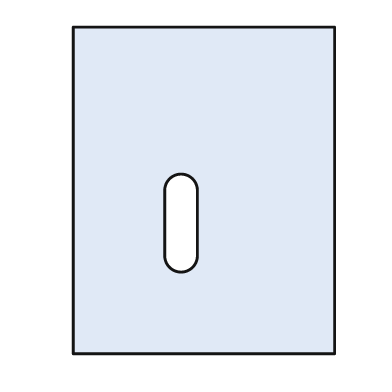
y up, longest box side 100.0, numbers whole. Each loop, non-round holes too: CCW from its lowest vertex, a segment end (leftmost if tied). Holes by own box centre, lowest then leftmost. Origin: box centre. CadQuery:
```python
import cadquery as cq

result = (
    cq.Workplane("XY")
    .moveTo(-40.0, -50.0)
    .lineTo(40.0, -50.0)
    .lineTo(40.0, 50.0)
    .lineTo(-40.0, 50.0)
    .close()
    .moveTo(-12.0, -20.0)
    .threePointArc((-7.0, -25.0), (-2.0, -20.0))
    .lineTo(-2.0, 0.0)
    .threePointArc((-7.0, 5.0), (-12.0, 0.0))
    .close()
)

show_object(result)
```